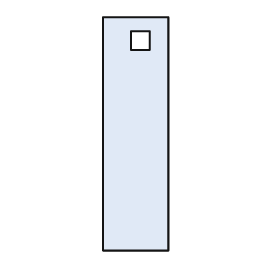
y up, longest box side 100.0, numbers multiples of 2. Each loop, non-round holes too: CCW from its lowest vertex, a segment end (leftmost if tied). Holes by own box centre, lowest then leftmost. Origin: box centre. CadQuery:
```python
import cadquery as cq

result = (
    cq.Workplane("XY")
    .moveTo(-14.0, -50.0)
    .lineTo(14.0, -50.0)
    .lineTo(14.0, 50.0)
    .lineTo(-14.0, 50.0)
    .close()
    .moveTo(-2.0, 36.0)
    .lineTo(6.0, 36.0)
    .lineTo(6.0, 44.0)
    .lineTo(-2.0, 44.0)
    .close()
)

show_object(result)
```